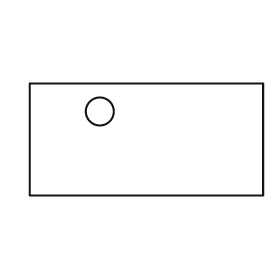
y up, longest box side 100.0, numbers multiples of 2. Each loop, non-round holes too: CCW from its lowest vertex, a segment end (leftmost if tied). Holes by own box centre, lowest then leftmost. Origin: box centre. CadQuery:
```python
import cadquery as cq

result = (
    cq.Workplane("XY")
    .moveTo(-50.0, -24.0)
    .lineTo(50.0, -24.0)
    .lineTo(50.0, 24.0)
    .lineTo(-50.0, 24.0)
    .close()
    .moveTo(-20.0, 12.0)
    .circle(6.0)
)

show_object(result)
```